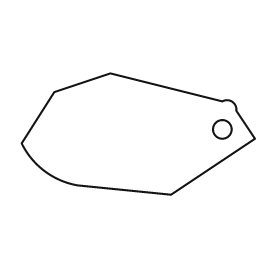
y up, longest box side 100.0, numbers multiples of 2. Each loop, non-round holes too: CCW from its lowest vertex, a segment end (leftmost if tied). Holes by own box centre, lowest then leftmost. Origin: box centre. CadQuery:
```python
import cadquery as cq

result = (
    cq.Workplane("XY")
    .moveTo(14.0, -26.0)
    .lineTo(50.0, -2.0)
    .lineTo(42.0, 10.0)
    .threePointArc((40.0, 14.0), (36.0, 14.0))
    .lineTo(-12.0, 26.0)
    .lineTo(-36.0, 18.0)
    .lineTo(-50.0, -4.0)
    .threePointArc((-40.0, -16.0), (-26.0, -22.0))
    .close()
    .moveTo(36.0, 2.0)
    .circle(4.0)
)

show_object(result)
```